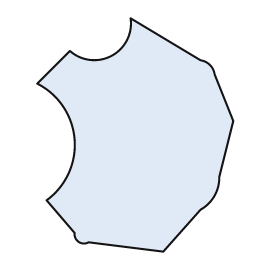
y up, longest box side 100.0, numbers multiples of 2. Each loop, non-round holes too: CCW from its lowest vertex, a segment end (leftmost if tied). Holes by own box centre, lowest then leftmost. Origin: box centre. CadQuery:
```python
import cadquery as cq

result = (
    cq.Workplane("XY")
    .moveTo(12.0, -50.0)
    .lineTo(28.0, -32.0)
    .threePointArc((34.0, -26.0), (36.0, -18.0))
    .lineTo(42.0, 6.0)
    .lineTo(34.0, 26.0)
    .threePointArc((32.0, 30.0), (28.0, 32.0))
    .lineTo(-2.0, 50.0)
    .threePointArc((-10.0, 34.0), (-28.0, 36.0))
    .lineTo(-42.0, 22.0)
    .threePointArc((-26.0, -2.0), (-38.0, -28.0))
    .lineTo(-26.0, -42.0)
    .threePointArc((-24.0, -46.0), (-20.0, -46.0))
    .close()
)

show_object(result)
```